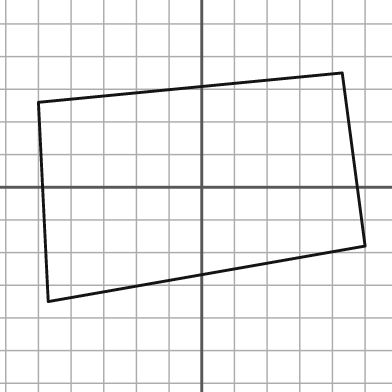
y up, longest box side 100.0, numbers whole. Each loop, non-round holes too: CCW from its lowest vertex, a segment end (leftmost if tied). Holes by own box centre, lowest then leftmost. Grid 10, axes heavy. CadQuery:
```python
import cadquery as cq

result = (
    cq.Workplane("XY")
    .moveTo(-47.0, -35.0)
    .lineTo(50.0, -18.0)
    .lineTo(43.0, 35.0)
    .lineTo(-50.0, 26.0)
    .close()
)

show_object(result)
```